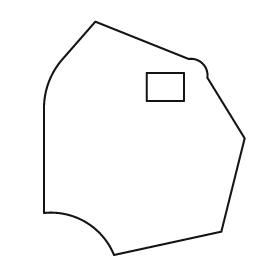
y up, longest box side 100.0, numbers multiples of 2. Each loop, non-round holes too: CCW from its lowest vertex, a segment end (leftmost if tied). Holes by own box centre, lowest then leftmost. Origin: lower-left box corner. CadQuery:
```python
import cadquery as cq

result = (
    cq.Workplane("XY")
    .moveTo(30.0, 0.0)
    .lineTo(76.0, 10.0)
    .lineTo(86.0, 50.0)
    .lineTo(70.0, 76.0)
    .threePointArc((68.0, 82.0), (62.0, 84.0))
    .lineTo(22.0, 100.0)
    .lineTo(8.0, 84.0)
    .threePointArc((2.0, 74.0), (0.0, 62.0))
    .lineTo(0.0, 18.0)
    .threePointArc((18.0, 14.0), (30.0, 0.0))
    .close()
    .moveTo(44.0, 66.0)
    .lineTo(60.0, 66.0)
    .lineTo(60.0, 78.0)
    .lineTo(44.0, 78.0)
    .close()
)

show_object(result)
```